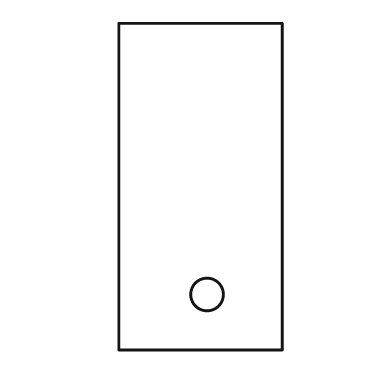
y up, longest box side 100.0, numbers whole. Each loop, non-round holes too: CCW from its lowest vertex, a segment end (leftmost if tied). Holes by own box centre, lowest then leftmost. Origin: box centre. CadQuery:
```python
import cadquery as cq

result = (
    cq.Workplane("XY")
    .moveTo(-25.0, -50.0)
    .lineTo(25.0, -50.0)
    .lineTo(25.0, 50.0)
    .lineTo(-25.0, 50.0)
    .close()
    .moveTo(2.0, -33.0)
    .circle(5.0)
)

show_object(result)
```